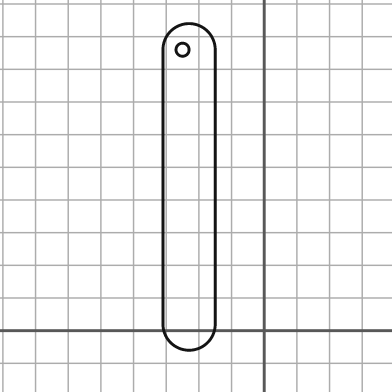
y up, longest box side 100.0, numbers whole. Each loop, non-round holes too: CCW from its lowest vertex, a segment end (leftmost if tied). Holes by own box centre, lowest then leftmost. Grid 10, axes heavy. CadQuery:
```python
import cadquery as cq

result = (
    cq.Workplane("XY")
    .moveTo(-31.0, 2.0)
    .threePointArc((-23.0, -6.0), (-15.0, 2.0))
    .lineTo(-15.0, 86.0)
    .threePointArc((-23.0, 94.0), (-31.0, 86.0))
    .close()
    .moveTo(-25.0, 86.0)
    .circle(2.0)
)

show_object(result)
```